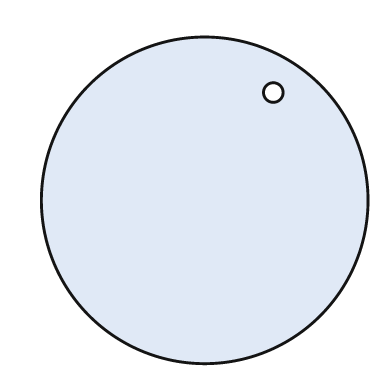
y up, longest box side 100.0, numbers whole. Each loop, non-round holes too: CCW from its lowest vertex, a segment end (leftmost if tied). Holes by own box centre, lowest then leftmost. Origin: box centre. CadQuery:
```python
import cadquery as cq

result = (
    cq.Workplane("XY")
    .moveTo(0.0, 0.0)
    .circle(50.0)
    .moveTo(21.0, 33.0)
    .circle(3.0)
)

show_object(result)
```